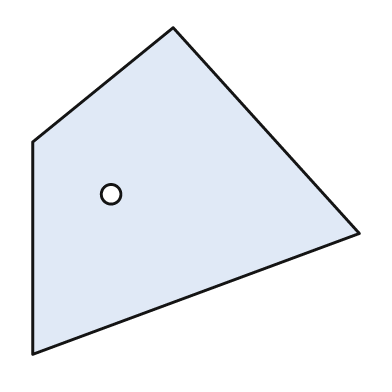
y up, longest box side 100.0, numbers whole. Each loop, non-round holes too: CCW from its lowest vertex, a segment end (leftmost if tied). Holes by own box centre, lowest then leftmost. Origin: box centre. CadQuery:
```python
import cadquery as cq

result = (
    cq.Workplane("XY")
    .moveTo(-50.0, -50.0)
    .lineTo(50.0, -13.0)
    .lineTo(-7.0, 50.0)
    .lineTo(-50.0, 15.0)
    .close()
    .moveTo(-26.0, -1.0)
    .circle(3.0)
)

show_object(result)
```